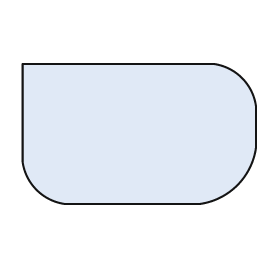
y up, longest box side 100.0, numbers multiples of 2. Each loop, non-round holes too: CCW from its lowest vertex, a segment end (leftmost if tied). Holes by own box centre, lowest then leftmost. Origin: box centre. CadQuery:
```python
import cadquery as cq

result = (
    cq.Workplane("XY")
    .moveTo(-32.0, -30.0)
    .lineTo(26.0, -30.0)
    .threePointArc((42.0, -22.0), (50.0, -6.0))
    .lineTo(50.0, 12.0)
    .threePointArc((44.0, 24.0), (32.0, 30.0))
    .lineTo(-50.0, 30.0)
    .lineTo(-50.0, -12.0)
    .threePointArc((-44.0, -24.0), (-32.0, -30.0))
    .close()
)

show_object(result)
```